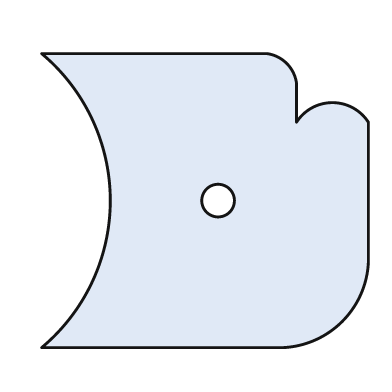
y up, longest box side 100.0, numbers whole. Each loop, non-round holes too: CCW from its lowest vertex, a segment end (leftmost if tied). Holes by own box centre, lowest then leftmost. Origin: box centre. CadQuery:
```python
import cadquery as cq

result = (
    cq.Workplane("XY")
    .moveTo(-50.0, -45.0)
    .lineTo(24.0, -45.0)
    .threePointArc((42.0, -37.0), (50.0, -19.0))
    .lineTo(50.0, 24.0)
    .threePointArc((39.0, 30.0), (28.0, 24.0))
    .lineTo(28.0, 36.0)
    .threePointArc((25.0, 42.0), (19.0, 45.0))
    .lineTo(-50.0, 45.0)
    .threePointArc((-29.0, 0.0), (-50.0, -45.0))
    .close()
    .moveTo(4.0, 0.0)
    .circle(5.0)
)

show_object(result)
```